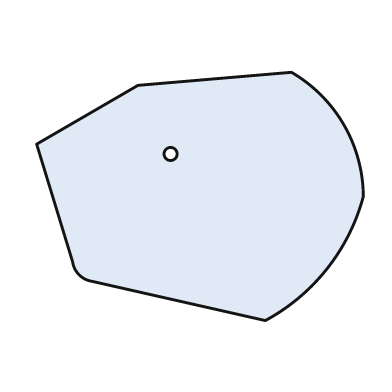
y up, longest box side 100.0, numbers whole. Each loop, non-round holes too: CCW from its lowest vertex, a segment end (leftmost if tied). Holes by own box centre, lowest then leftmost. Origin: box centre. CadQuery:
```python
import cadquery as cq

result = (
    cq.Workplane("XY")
    .moveTo(20.0, -38.0)
    .threePointArc((39.0, -22.0), (50.0, 0.0))
    .threePointArc((44.0, 22.0), (28.0, 38.0))
    .lineTo(-19.0, 34.0)
    .lineTo(-50.0, 16.0)
    .lineTo(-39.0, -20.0)
    .threePointArc((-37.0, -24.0), (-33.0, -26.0))
    .close()
    .moveTo(-9.0, 13.0)
    .circle(2.0)
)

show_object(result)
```